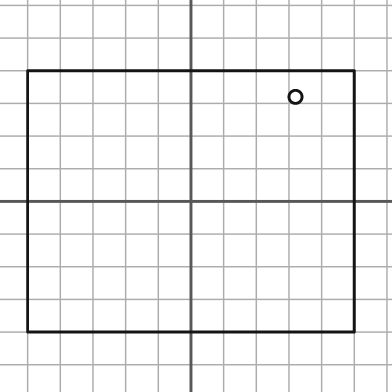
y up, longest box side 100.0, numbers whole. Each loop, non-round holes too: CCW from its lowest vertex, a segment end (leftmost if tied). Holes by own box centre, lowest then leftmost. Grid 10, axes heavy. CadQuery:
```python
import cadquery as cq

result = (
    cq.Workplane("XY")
    .moveTo(-50.0, -40.0)
    .lineTo(50.0, -40.0)
    .lineTo(50.0, 40.0)
    .lineTo(-50.0, 40.0)
    .close()
    .moveTo(32.0, 32.0)
    .circle(2.0)
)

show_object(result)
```